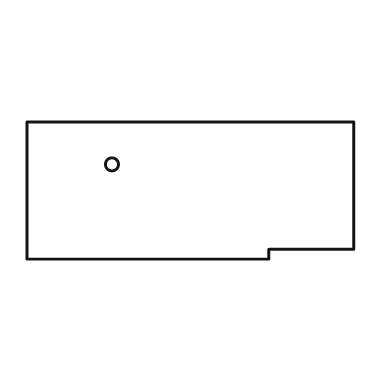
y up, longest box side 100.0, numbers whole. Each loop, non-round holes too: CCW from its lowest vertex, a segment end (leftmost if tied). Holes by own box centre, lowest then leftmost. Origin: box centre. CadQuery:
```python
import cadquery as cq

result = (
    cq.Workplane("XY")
    .moveTo(-50.0, -21.0)
    .lineTo(24.0, -21.0)
    .lineTo(24.0, -18.0)
    .lineTo(50.0, -18.0)
    .lineTo(50.0, 21.0)
    .lineTo(-50.0, 21.0)
    .close()
    .moveTo(-24.0, 8.0)
    .circle(2.0)
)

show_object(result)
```